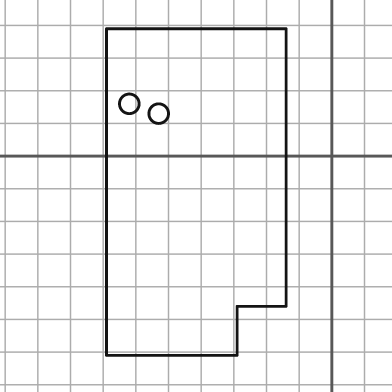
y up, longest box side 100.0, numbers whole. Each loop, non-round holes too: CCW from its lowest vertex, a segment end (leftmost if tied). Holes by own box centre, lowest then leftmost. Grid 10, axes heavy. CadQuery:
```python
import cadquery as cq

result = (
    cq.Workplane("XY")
    .moveTo(-69.0, -61.0)
    .lineTo(-29.0, -61.0)
    .lineTo(-29.0, -46.0)
    .lineTo(-14.0, -46.0)
    .lineTo(-14.0, 39.0)
    .lineTo(-69.0, 39.0)
    .close()
    .moveTo(-53.0, 13.0)
    .circle(3.0)
    .moveTo(-62.0, 16.0)
    .circle(3.0)
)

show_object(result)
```